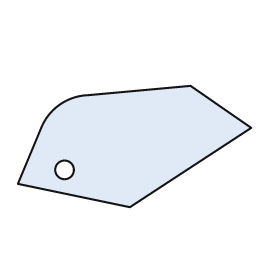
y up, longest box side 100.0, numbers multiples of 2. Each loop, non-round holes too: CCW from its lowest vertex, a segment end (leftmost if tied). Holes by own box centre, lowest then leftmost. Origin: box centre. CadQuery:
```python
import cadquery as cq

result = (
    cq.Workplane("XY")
    .moveTo(-2.0, -26.0)
    .lineTo(50.0, 8.0)
    .lineTo(24.0, 26.0)
    .lineTo(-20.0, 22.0)
    .threePointArc((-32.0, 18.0), (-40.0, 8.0))
    .lineTo(-50.0, -16.0)
    .close()
    .moveTo(-30.0, -10.0)
    .circle(4.0)
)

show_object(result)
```